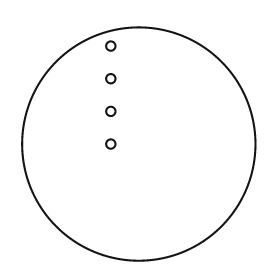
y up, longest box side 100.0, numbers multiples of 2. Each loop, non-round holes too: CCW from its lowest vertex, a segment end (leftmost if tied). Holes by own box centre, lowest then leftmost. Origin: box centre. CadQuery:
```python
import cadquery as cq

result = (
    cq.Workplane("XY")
    .moveTo(0.0, 0.0)
    .circle(50.0)
    .moveTo(-12.0, 0.0)
    .circle(2.0)
    .moveTo(-12.0, 14.0)
    .circle(2.0)
    .moveTo(-12.0, 28.0)
    .circle(2.0)
    .moveTo(-12.0, 42.0)
    .circle(2.0)
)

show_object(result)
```